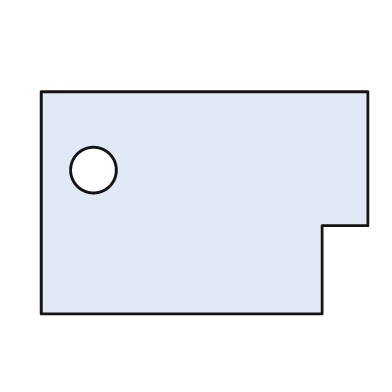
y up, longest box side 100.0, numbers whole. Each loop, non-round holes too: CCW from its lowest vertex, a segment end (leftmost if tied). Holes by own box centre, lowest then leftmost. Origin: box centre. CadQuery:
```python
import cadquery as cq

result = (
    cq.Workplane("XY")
    .moveTo(-50.0, -34.0)
    .lineTo(36.0, -34.0)
    .lineTo(36.0, -7.0)
    .lineTo(50.0, -7.0)
    .lineTo(50.0, 34.0)
    .lineTo(-50.0, 34.0)
    .close()
    .moveTo(-34.0, 10.0)
    .circle(7.0)
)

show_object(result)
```